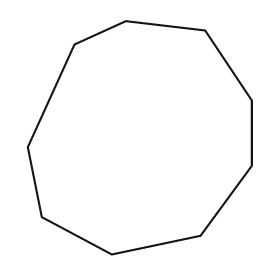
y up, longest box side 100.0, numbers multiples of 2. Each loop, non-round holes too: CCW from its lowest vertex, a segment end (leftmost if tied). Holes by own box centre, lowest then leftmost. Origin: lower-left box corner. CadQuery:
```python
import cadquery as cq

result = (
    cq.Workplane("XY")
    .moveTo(36.0, 0.0)
    .lineTo(74.0, 8.0)
    .lineTo(96.0, 38.0)
    .lineTo(96.0, 66.0)
    .lineTo(76.0, 96.0)
    .lineTo(42.0, 100.0)
    .lineTo(20.0, 90.0)
    .lineTo(0.0, 46.0)
    .lineTo(6.0, 16.0)
    .close()
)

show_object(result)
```